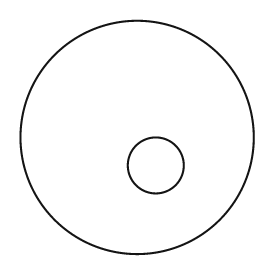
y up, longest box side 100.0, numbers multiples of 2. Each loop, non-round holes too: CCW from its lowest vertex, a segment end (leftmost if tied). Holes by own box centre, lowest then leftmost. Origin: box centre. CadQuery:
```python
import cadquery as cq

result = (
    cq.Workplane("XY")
    .moveTo(0.0, 0.0)
    .circle(50.0)
    .moveTo(8.0, -12.0)
    .circle(12.0)
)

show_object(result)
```